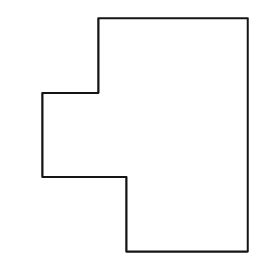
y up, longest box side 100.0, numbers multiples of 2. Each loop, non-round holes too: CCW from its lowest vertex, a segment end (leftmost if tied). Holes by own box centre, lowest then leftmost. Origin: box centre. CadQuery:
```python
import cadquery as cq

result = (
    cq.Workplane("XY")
    .moveTo(-8.0, -50.0)
    .lineTo(44.0, -50.0)
    .lineTo(44.0, 50.0)
    .lineTo(-20.0, 50.0)
    .lineTo(-20.0, 18.0)
    .lineTo(-44.0, 18.0)
    .lineTo(-44.0, -18.0)
    .lineTo(-8.0, -18.0)
    .close()
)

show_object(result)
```